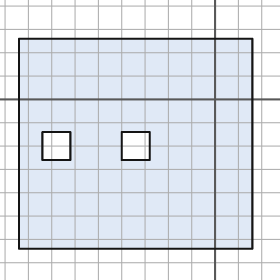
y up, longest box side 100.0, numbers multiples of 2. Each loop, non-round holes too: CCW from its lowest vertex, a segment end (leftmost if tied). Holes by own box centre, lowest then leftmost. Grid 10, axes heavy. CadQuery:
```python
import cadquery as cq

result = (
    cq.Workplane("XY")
    .moveTo(-84.0, -64.0)
    .lineTo(16.0, -64.0)
    .lineTo(16.0, 26.0)
    .lineTo(-84.0, 26.0)
    .close()
    .moveTo(-74.0, -26.0)
    .lineTo(-62.0, -26.0)
    .lineTo(-62.0, -14.0)
    .lineTo(-74.0, -14.0)
    .close()
    .moveTo(-40.0, -26.0)
    .lineTo(-28.0, -26.0)
    .lineTo(-28.0, -14.0)
    .lineTo(-40.0, -14.0)
    .close()
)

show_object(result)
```